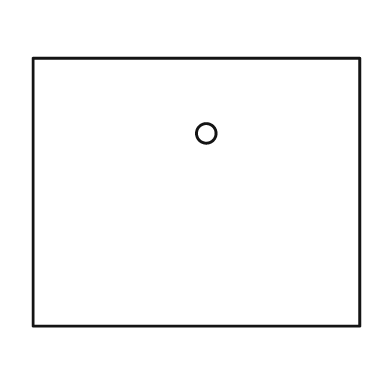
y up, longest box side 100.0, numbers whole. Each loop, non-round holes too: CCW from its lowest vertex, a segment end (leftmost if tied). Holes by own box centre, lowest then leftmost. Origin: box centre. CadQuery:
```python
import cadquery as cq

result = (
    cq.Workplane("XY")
    .moveTo(-50.0, -41.0)
    .lineTo(50.0, -41.0)
    .lineTo(50.0, 41.0)
    .lineTo(-50.0, 41.0)
    .close()
    .moveTo(3.0, 18.0)
    .circle(3.0)
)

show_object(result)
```